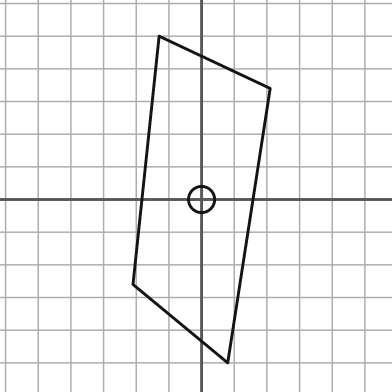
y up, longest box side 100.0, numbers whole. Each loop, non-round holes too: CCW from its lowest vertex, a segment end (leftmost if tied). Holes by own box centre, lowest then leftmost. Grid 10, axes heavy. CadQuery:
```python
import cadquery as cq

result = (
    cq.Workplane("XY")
    .moveTo(8.0, -50.0)
    .lineTo(21.0, 34.0)
    .lineTo(-13.0, 50.0)
    .lineTo(-21.0, -26.0)
    .close()
    .moveTo(0.0, 0.0)
    .circle(4.0)
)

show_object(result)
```